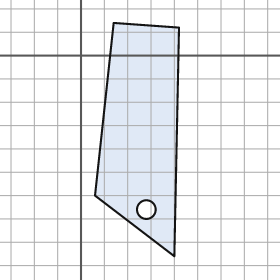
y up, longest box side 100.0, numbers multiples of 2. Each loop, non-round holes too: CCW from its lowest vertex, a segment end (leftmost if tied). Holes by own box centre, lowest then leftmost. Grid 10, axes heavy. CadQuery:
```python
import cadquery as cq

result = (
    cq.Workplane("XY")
    .moveTo(40.0, -86.0)
    .lineTo(42.0, 12.0)
    .lineTo(14.0, 14.0)
    .lineTo(6.0, -60.0)
    .close()
    .moveTo(28.0, -66.0)
    .circle(4.0)
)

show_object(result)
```